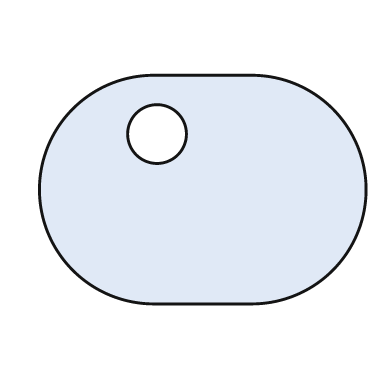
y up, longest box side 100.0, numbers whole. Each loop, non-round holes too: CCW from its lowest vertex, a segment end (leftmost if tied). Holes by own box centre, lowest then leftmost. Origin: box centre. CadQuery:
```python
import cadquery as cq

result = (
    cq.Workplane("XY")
    .moveTo(-15.0, -35.0)
    .lineTo(15.0, -35.0)
    .threePointArc((50.0, 0.0), (15.0, 35.0))
    .lineTo(-15.0, 35.0)
    .threePointArc((-50.0, 0.0), (-15.0, -35.0))
    .close()
    .moveTo(-14.0, 17.0)
    .circle(9.0)
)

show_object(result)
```